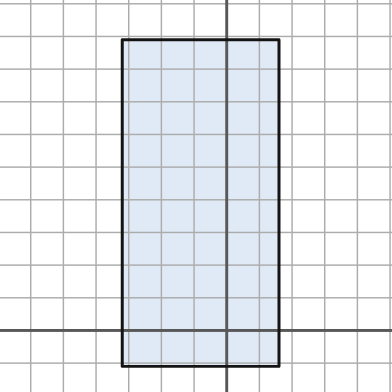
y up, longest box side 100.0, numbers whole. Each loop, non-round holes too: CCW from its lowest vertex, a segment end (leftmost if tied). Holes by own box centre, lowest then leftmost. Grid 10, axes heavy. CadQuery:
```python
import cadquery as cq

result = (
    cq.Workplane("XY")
    .moveTo(-32.0, -11.0)
    .lineTo(16.0, -11.0)
    .lineTo(16.0, 89.0)
    .lineTo(-32.0, 89.0)
    .close()
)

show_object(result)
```